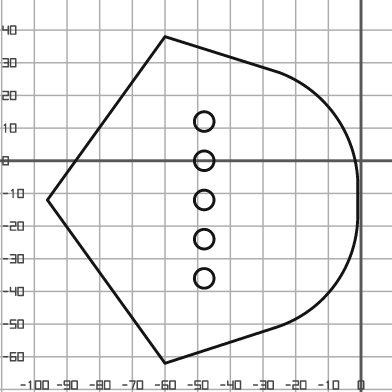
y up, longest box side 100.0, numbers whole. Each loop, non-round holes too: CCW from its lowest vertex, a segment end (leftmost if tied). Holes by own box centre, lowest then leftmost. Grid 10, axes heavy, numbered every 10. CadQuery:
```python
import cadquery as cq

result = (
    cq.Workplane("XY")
    .moveTo(-60.0, -62.0)
    .lineTo(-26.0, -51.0)
    .threePointArc((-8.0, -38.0), (-1.0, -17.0))
    .lineTo(-1.0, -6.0)
    .threePointArc((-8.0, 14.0), (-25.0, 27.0))
    .lineTo(-60.0, 38.0)
    .lineTo(-96.0, -12.0)
    .close()
    .moveTo(-48.0, -36.0)
    .circle(3.0)
    .moveTo(-48.0, -24.0)
    .circle(3.0)
    .moveTo(-48.0, -12.0)
    .circle(3.0)
    .moveTo(-48.0, 0.0)
    .circle(3.0)
    .moveTo(-48.0, 12.0)
    .circle(3.0)
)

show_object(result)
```